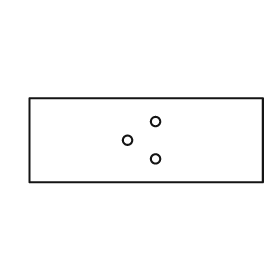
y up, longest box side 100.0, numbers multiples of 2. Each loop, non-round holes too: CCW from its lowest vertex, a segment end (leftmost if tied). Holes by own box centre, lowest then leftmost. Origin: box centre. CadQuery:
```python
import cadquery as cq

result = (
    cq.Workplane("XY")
    .moveTo(-50.0, -18.0)
    .lineTo(50.0, -18.0)
    .lineTo(50.0, 18.0)
    .lineTo(-50.0, 18.0)
    .close()
    .moveTo(4.0, -8.0)
    .circle(2.0)
    .moveTo(-8.0, 0.0)
    .circle(2.0)
    .moveTo(4.0, 8.0)
    .circle(2.0)
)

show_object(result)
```